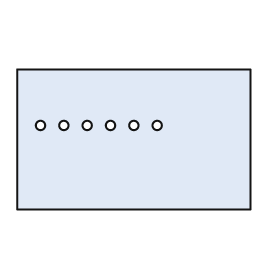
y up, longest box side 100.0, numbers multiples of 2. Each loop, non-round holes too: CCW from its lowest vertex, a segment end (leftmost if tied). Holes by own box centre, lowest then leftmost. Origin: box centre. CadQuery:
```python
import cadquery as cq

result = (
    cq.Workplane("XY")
    .moveTo(-50.0, -30.0)
    .lineTo(50.0, -30.0)
    .lineTo(50.0, 30.0)
    .lineTo(-50.0, 30.0)
    .close()
    .moveTo(-40.0, 6.0)
    .circle(2.0)
    .moveTo(-30.0, 6.0)
    .circle(2.0)
    .moveTo(-20.0, 6.0)
    .circle(2.0)
    .moveTo(-10.0, 6.0)
    .circle(2.0)
    .moveTo(0.0, 6.0)
    .circle(2.0)
    .moveTo(10.0, 6.0)
    .circle(2.0)
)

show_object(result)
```